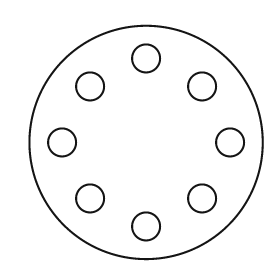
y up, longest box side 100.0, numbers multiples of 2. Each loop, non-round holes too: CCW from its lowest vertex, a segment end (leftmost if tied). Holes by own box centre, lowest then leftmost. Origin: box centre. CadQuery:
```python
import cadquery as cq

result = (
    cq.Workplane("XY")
    .moveTo(0.0, 0.0)
    .circle(50.0)
    .moveTo(0.0, -36.0)
    .circle(6.0)
    .moveTo(-24.0, -24.0)
    .circle(6.0)
    .moveTo(24.0, -24.0)
    .circle(6.0)
    .moveTo(-36.0, 0.0)
    .circle(6.0)
    .moveTo(36.0, 0.0)
    .circle(6.0)
    .moveTo(-24.0, 24.0)
    .circle(6.0)
    .moveTo(24.0, 24.0)
    .circle(6.0)
    .moveTo(0.0, 36.0)
    .circle(6.0)
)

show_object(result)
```